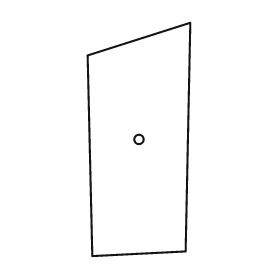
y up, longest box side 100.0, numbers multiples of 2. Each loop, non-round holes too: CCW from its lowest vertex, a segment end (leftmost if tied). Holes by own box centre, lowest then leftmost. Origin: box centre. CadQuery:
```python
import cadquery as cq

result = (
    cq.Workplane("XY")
    .moveTo(-20.0, -50.0)
    .lineTo(20.0, -48.0)
    .lineTo(22.0, 50.0)
    .lineTo(-22.0, 36.0)
    .close()
    .moveTo(0.0, 0.0)
    .circle(2.0)
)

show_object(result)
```